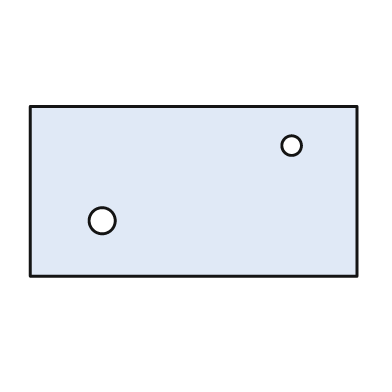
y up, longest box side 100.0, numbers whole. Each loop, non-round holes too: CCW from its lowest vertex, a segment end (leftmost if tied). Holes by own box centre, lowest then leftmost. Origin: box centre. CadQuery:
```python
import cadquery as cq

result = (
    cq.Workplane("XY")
    .moveTo(-50.0, -26.0)
    .lineTo(50.0, -26.0)
    .lineTo(50.0, 26.0)
    .lineTo(-50.0, 26.0)
    .close()
    .moveTo(-28.0, -9.0)
    .circle(4.0)
    .moveTo(30.0, 14.0)
    .circle(3.0)
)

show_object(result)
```